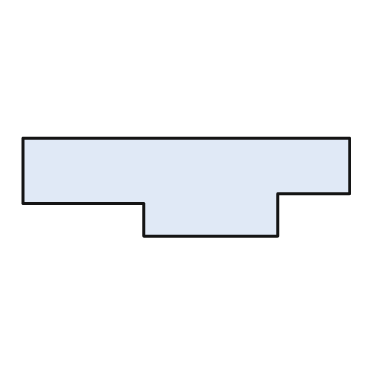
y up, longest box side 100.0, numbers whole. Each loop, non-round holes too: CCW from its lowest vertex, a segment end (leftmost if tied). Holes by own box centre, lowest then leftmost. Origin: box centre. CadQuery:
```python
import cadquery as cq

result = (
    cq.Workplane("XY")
    .moveTo(-13.0, -15.0)
    .lineTo(28.0, -15.0)
    .lineTo(28.0, -2.0)
    .lineTo(50.0, -2.0)
    .lineTo(50.0, 15.0)
    .lineTo(-50.0, 15.0)
    .lineTo(-50.0, -5.0)
    .lineTo(-13.0, -5.0)
    .close()
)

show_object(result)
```